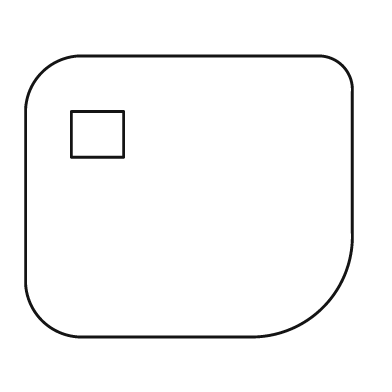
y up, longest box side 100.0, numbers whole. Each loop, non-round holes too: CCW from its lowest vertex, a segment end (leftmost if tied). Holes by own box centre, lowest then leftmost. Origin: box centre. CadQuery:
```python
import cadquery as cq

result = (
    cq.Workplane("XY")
    .moveTo(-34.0, -43.0)
    .lineTo(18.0, -43.0)
    .threePointArc((41.0, -34.0), (50.0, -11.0))
    .lineTo(50.0, 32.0)
    .threePointArc((47.0, 40.0), (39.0, 43.0))
    .lineTo(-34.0, 43.0)
    .threePointArc((-45.0, 38.0), (-50.0, 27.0))
    .lineTo(-50.0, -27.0)
    .threePointArc((-45.0, -38.0), (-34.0, -43.0))
    .close()
    .moveTo(-36.0, 12.0)
    .lineTo(-20.0, 12.0)
    .lineTo(-20.0, 26.0)
    .lineTo(-36.0, 26.0)
    .close()
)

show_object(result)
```